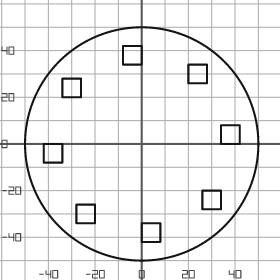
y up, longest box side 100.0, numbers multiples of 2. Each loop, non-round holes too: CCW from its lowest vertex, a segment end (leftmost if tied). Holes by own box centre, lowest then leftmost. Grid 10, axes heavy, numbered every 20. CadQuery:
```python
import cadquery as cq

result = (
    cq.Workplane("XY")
    .moveTo(0.0, 0.0)
    .circle(50.0)
    .moveTo(0.0, -42.0)
    .lineTo(8.0, -42.0)
    .lineTo(8.0, -34.0)
    .lineTo(0.0, -34.0)
    .close()
    .moveTo(-28.0, -34.0)
    .lineTo(-20.0, -34.0)
    .lineTo(-20.0, -26.0)
    .lineTo(-28.0, -26.0)
    .close()
    .moveTo(26.0, -28.0)
    .lineTo(34.0, -28.0)
    .lineTo(34.0, -20.0)
    .lineTo(26.0, -20.0)
    .close()
    .moveTo(-42.0, -8.0)
    .lineTo(-34.0, -8.0)
    .lineTo(-34.0, 0.0)
    .lineTo(-42.0, 0.0)
    .close()
    .moveTo(34.0, 0.0)
    .lineTo(42.0, 0.0)
    .lineTo(42.0, 8.0)
    .lineTo(34.0, 8.0)
    .close()
    .moveTo(-34.0, 20.0)
    .lineTo(-26.0, 20.0)
    .lineTo(-26.0, 28.0)
    .lineTo(-34.0, 28.0)
    .close()
    .moveTo(20.0, 26.0)
    .lineTo(28.0, 26.0)
    .lineTo(28.0, 34.0)
    .lineTo(20.0, 34.0)
    .close()
    .moveTo(-8.0, 34.0)
    .lineTo(0.0, 34.0)
    .lineTo(0.0, 42.0)
    .lineTo(-8.0, 42.0)
    .close()
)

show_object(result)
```